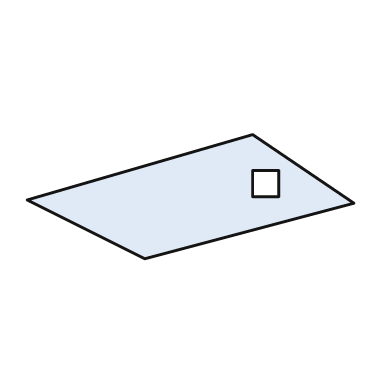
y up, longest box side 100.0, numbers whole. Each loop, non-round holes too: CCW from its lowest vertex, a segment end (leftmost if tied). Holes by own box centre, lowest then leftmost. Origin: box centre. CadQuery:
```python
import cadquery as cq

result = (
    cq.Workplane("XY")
    .moveTo(-14.0, -19.0)
    .lineTo(50.0, -2.0)
    .lineTo(19.0, 19.0)
    .lineTo(-50.0, -1.0)
    .close()
    .moveTo(19.0, 0.0)
    .lineTo(27.0, 0.0)
    .lineTo(27.0, 8.0)
    .lineTo(19.0, 8.0)
    .close()
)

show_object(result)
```